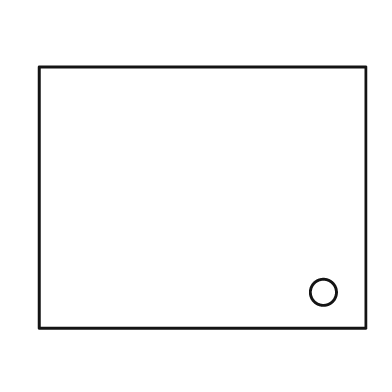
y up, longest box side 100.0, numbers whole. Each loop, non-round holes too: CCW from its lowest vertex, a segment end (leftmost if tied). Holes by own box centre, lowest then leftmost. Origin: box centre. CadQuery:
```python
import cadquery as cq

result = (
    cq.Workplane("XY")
    .moveTo(-50.0, -40.0)
    .lineTo(50.0, -40.0)
    .lineTo(50.0, 40.0)
    .lineTo(-50.0, 40.0)
    .close()
    .moveTo(37.0, -29.0)
    .circle(4.0)
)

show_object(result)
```